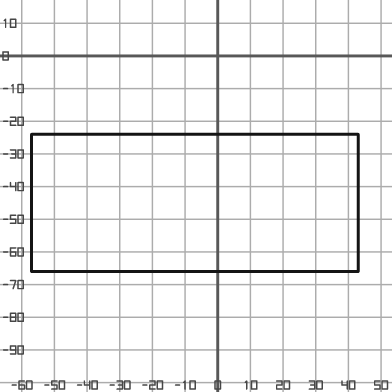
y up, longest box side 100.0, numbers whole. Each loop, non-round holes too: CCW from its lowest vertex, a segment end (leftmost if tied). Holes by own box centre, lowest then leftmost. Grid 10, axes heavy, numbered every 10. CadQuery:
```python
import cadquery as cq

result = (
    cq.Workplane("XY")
    .moveTo(-57.0, -66.0)
    .lineTo(43.0, -66.0)
    .lineTo(43.0, -24.0)
    .lineTo(-57.0, -24.0)
    .close()
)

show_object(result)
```